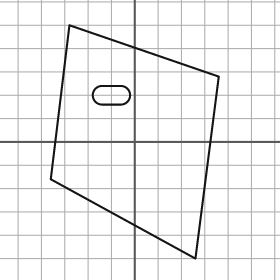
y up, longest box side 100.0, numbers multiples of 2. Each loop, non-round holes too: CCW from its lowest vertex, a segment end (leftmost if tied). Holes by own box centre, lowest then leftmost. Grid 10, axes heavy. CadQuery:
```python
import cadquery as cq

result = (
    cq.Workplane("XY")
    .moveTo(26.0, -50.0)
    .lineTo(36.0, 28.0)
    .lineTo(-28.0, 50.0)
    .lineTo(-36.0, -16.0)
    .close()
    .moveTo(-14.0, 16.0)
    .lineTo(-6.0, 16.0)
    .threePointArc((-2.0, 20.0), (-6.0, 24.0))
    .lineTo(-14.0, 24.0)
    .threePointArc((-18.0, 20.0), (-14.0, 16.0))
    .close()
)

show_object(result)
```